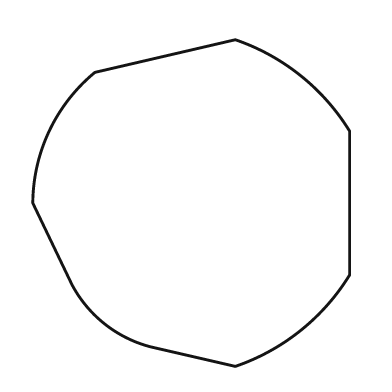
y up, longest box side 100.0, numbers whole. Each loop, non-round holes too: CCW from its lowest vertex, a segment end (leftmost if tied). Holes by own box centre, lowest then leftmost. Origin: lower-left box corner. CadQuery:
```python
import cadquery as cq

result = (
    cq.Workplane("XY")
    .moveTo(62.0, 0.0)
    .threePointArc((82.0, 11.0), (97.0, 28.0))
    .lineTo(97.0, 72.0)
    .threePointArc((82.0, 89.0), (62.0, 100.0))
    .lineTo(19.0, 90.0)
    .threePointArc((5.0, 72.0), (0.0, 50.0))
    .lineTo(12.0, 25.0)
    .threePointArc((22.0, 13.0), (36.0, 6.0))
    .close()
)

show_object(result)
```